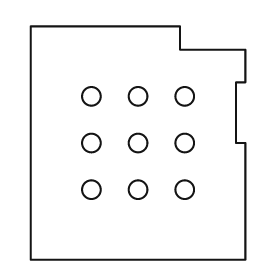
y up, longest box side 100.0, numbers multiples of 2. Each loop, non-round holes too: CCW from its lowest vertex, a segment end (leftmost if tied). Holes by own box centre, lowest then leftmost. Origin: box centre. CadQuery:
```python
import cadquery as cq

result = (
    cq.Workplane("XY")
    .moveTo(-46.0, -50.0)
    .lineTo(46.0, -50.0)
    .lineTo(46.0, 0.0)
    .lineTo(42.0, 0.0)
    .lineTo(42.0, 26.0)
    .lineTo(46.0, 26.0)
    .lineTo(46.0, 40.0)
    .lineTo(18.0, 40.0)
    .lineTo(18.0, 50.0)
    .lineTo(-46.0, 50.0)
    .close()
    .moveTo(-20.0, -20.0)
    .circle(4.0)
    .moveTo(0.0, -20.0)
    .circle(4.0)
    .moveTo(20.0, -20.0)
    .circle(4.0)
    .moveTo(-20.0, 0.0)
    .circle(4.0)
    .moveTo(0.0, 0.0)
    .circle(4.0)
    .moveTo(20.0, 0.0)
    .circle(4.0)
    .moveTo(-20.0, 20.0)
    .circle(4.0)
    .moveTo(0.0, 20.0)
    .circle(4.0)
    .moveTo(20.0, 20.0)
    .circle(4.0)
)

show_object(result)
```